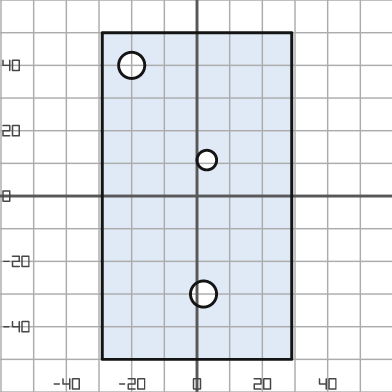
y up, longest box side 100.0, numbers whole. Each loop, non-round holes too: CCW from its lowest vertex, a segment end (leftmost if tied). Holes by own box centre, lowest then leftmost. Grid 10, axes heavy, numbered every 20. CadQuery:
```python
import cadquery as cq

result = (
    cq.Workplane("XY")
    .moveTo(-29.0, -50.0)
    .lineTo(29.0, -50.0)
    .lineTo(29.0, 50.0)
    .lineTo(-29.0, 50.0)
    .close()
    .moveTo(2.0, -30.0)
    .circle(4.0)
    .moveTo(3.0, 11.0)
    .circle(3.0)
    .moveTo(-20.0, 40.0)
    .circle(4.0)
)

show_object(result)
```